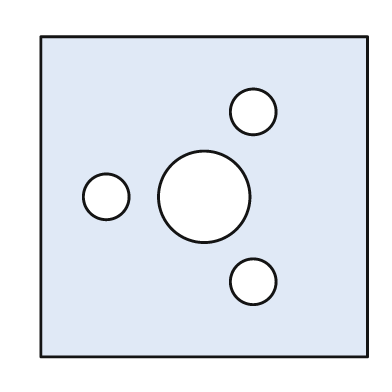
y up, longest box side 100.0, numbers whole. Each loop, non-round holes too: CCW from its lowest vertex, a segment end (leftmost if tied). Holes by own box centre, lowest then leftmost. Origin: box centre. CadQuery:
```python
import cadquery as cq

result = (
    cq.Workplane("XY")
    .moveTo(-50.0, -49.0)
    .lineTo(50.0, -49.0)
    .lineTo(50.0, 49.0)
    .lineTo(-50.0, 49.0)
    .close()
    .moveTo(15.0, -26.0)
    .circle(7.0)
    .moveTo(-30.0, 0.0)
    .circle(7.0)
    .moveTo(0.0, 0.0)
    .circle(14.0)
    .moveTo(15.0, 26.0)
    .circle(7.0)
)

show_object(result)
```